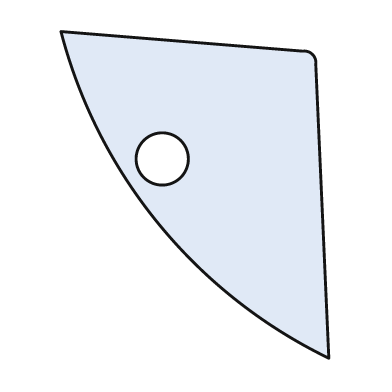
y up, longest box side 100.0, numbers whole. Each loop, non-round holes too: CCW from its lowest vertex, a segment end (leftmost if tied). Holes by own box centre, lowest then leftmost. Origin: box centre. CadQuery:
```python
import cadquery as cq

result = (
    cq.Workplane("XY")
    .moveTo(41.0, -50.0)
    .lineTo(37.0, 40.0)
    .threePointArc((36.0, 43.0), (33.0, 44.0))
    .lineTo(-41.0, 50.0)
    .threePointArc((-11.0, -9.0), (41.0, -50.0))
    .close()
    .moveTo(-10.0, 11.0)
    .circle(8.0)
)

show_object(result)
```